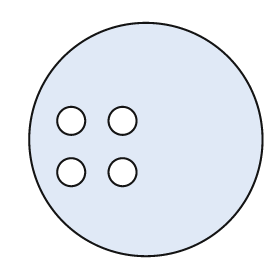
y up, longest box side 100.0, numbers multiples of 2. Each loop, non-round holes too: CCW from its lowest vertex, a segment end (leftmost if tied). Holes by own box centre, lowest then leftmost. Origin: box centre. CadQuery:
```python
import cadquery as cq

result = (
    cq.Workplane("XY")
    .moveTo(0.0, 0.0)
    .circle(50.0)
    .moveTo(-32.0, -14.0)
    .circle(6.0)
    .moveTo(-10.0, -14.0)
    .circle(6.0)
    .moveTo(-32.0, 8.0)
    .circle(6.0)
    .moveTo(-10.0, 8.0)
    .circle(6.0)
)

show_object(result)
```